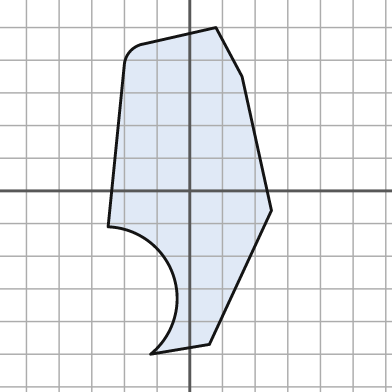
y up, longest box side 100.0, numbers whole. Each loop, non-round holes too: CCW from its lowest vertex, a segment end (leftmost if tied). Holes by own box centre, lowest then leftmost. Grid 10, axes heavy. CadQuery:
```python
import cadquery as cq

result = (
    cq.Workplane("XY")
    .moveTo(-12.0, -50.0)
    .lineTo(6.0, -47.0)
    .lineTo(25.0, -6.0)
    .lineTo(16.0, 35.0)
    .lineTo(8.0, 50.0)
    .lineTo(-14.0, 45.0)
    .threePointArc((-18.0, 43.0), (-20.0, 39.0))
    .lineTo(-25.0, -11.0)
    .threePointArc((-5.0, -26.0), (-12.0, -50.0))
    .close()
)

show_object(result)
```